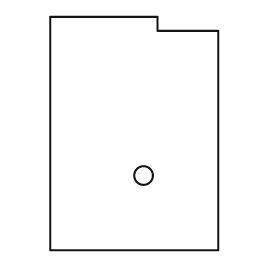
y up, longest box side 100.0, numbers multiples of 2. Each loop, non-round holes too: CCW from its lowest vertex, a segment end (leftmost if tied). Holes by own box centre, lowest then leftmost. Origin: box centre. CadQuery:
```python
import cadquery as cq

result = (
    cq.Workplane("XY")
    .moveTo(-36.0, -50.0)
    .lineTo(36.0, -50.0)
    .lineTo(36.0, 44.0)
    .lineTo(10.0, 44.0)
    .lineTo(10.0, 50.0)
    .lineTo(-36.0, 50.0)
    .close()
    .moveTo(4.0, -18.0)
    .circle(4.0)
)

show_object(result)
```